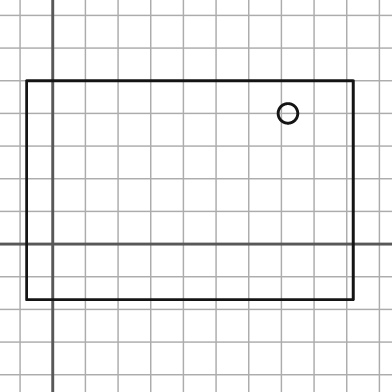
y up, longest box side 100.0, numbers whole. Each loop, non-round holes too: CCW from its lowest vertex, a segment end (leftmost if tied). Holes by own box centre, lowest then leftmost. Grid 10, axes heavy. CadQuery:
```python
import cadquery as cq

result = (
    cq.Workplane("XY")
    .moveTo(-8.0, -17.0)
    .lineTo(92.0, -17.0)
    .lineTo(92.0, 50.0)
    .lineTo(-8.0, 50.0)
    .close()
    .moveTo(72.0, 40.0)
    .circle(3.0)
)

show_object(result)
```